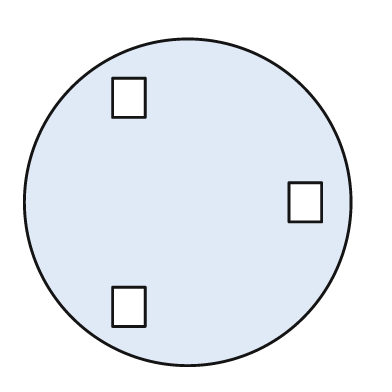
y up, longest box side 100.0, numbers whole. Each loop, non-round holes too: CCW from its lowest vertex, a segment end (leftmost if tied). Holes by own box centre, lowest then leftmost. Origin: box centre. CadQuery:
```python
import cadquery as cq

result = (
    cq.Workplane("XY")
    .moveTo(0.0, 0.0)
    .circle(50.0)
    .moveTo(-23.0, -38.0)
    .lineTo(-13.0, -38.0)
    .lineTo(-13.0, -26.0)
    .lineTo(-23.0, -26.0)
    .close()
    .moveTo(31.0, -6.0)
    .lineTo(41.0, -6.0)
    .lineTo(41.0, 6.0)
    .lineTo(31.0, 6.0)
    .close()
    .moveTo(-23.0, 26.0)
    .lineTo(-13.0, 26.0)
    .lineTo(-13.0, 38.0)
    .lineTo(-23.0, 38.0)
    .close()
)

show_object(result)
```